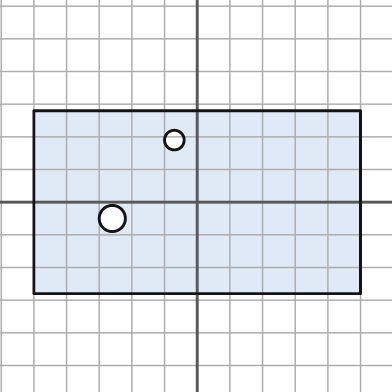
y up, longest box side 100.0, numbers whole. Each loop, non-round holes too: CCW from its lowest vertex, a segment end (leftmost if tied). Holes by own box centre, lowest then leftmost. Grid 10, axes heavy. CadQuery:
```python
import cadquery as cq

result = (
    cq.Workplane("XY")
    .moveTo(-50.0, -28.0)
    .lineTo(50.0, -28.0)
    .lineTo(50.0, 28.0)
    .lineTo(-50.0, 28.0)
    .close()
    .moveTo(-26.0, -5.0)
    .circle(4.0)
    .moveTo(-7.0, 19.0)
    .circle(3.0)
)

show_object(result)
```